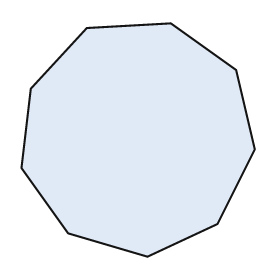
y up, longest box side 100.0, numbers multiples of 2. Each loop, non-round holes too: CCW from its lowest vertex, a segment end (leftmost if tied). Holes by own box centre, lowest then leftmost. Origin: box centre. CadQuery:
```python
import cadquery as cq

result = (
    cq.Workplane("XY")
    .moveTo(4.0, -50.0)
    .lineTo(34.0, -36.0)
    .lineTo(50.0, -4.0)
    .lineTo(42.0, 30.0)
    .lineTo(14.0, 50.0)
    .lineTo(-22.0, 48.0)
    .lineTo(-46.0, 22.0)
    .lineTo(-50.0, -12.0)
    .lineTo(-30.0, -40.0)
    .close()
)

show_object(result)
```